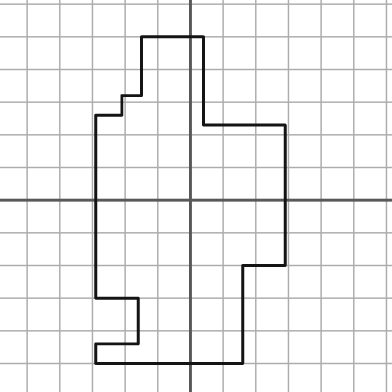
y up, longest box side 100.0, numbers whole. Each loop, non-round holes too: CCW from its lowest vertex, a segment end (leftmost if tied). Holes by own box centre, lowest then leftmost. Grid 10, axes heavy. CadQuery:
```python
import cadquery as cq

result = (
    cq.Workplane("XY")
    .moveTo(-29.0, -50.0)
    .lineTo(16.0, -50.0)
    .lineTo(16.0, -20.0)
    .lineTo(29.0, -20.0)
    .lineTo(29.0, 23.0)
    .lineTo(4.0, 23.0)
    .lineTo(4.0, 50.0)
    .lineTo(-15.0, 50.0)
    .lineTo(-15.0, 32.0)
    .lineTo(-21.0, 32.0)
    .lineTo(-21.0, 26.0)
    .lineTo(-29.0, 26.0)
    .lineTo(-29.0, -30.0)
    .lineTo(-16.0, -30.0)
    .lineTo(-16.0, -44.0)
    .lineTo(-29.0, -44.0)
    .close()
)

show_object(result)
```